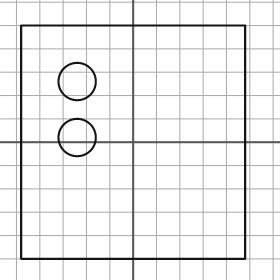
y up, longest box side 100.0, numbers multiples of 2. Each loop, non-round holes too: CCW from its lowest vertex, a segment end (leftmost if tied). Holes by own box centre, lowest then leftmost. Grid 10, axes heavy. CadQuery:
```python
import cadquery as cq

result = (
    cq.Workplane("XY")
    .moveTo(-48.0, -50.0)
    .lineTo(48.0, -50.0)
    .lineTo(48.0, 50.0)
    .lineTo(-48.0, 50.0)
    .close()
    .moveTo(-24.0, 2.0)
    .circle(8.0)
    .moveTo(-24.0, 26.0)
    .circle(8.0)
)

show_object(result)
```